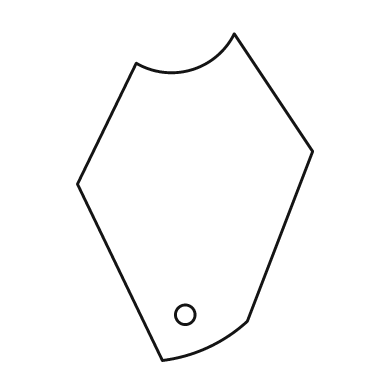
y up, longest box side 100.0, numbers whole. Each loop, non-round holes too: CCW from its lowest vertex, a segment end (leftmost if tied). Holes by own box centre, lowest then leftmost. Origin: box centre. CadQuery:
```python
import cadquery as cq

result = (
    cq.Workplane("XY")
    .moveTo(-10.0, -50.0)
    .threePointArc((4.0, -46.0), (16.0, -38.0))
    .lineTo(36.0, 14.0)
    .lineTo(12.0, 50.0)
    .threePointArc((-1.0, 39.0), (-18.0, 41.0))
    .lineTo(-36.0, 4.0)
    .close()
    .moveTo(-3.0, -36.0)
    .circle(3.0)
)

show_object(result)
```